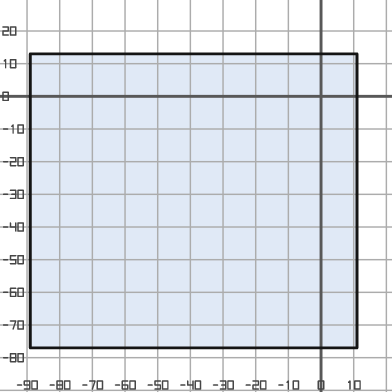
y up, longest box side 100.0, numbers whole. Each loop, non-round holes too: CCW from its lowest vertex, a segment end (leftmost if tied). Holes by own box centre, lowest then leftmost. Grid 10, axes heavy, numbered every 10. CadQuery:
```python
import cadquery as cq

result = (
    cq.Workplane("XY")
    .moveTo(-89.0, -77.0)
    .lineTo(11.0, -77.0)
    .lineTo(11.0, 13.0)
    .lineTo(-89.0, 13.0)
    .close()
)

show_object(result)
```